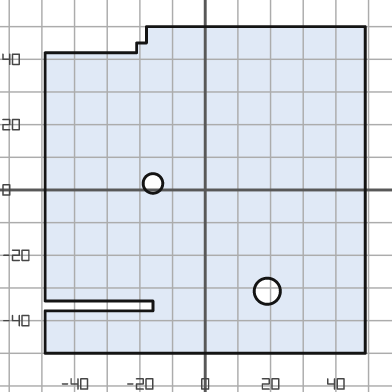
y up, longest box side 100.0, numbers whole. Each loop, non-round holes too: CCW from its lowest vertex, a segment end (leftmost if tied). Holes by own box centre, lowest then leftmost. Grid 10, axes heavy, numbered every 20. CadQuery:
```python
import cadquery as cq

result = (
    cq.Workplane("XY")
    .moveTo(-49.0, -50.0)
    .lineTo(49.0, -50.0)
    .lineTo(49.0, 50.0)
    .lineTo(-18.0, 50.0)
    .lineTo(-18.0, 45.0)
    .lineTo(-21.0, 45.0)
    .lineTo(-21.0, 42.0)
    .lineTo(-49.0, 42.0)
    .lineTo(-49.0, -34.0)
    .lineTo(-16.0, -34.0)
    .lineTo(-16.0, -37.0)
    .lineTo(-49.0, -37.0)
    .close()
    .moveTo(19.0, -31.0)
    .circle(4.0)
    .moveTo(-16.0, 2.0)
    .circle(3.0)
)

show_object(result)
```